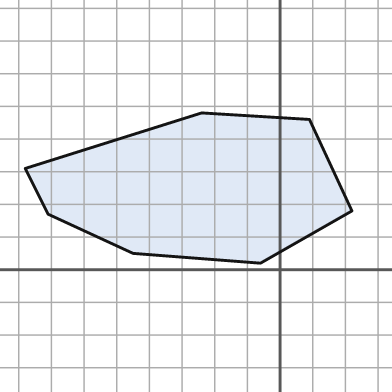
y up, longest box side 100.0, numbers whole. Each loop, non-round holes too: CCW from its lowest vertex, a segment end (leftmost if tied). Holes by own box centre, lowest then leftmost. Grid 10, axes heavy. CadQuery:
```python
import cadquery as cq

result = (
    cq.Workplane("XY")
    .moveTo(-6.0, 2.0)
    .lineTo(22.0, 18.0)
    .lineTo(9.0, 46.0)
    .lineTo(-24.0, 48.0)
    .lineTo(-78.0, 31.0)
    .lineTo(-71.0, 17.0)
    .lineTo(-45.0, 5.0)
    .close()
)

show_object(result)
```